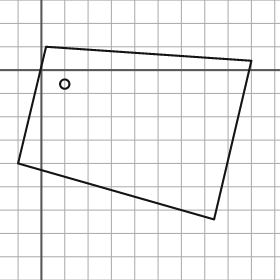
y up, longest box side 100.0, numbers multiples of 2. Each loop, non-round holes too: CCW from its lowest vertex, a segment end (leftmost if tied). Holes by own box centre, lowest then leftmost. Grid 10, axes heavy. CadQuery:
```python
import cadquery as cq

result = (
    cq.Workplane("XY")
    .moveTo(74.0, -64.0)
    .lineTo(90.0, 4.0)
    .lineTo(2.0, 10.0)
    .lineTo(-10.0, -40.0)
    .close()
    .moveTo(10.0, -6.0)
    .circle(2.0)
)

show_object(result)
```